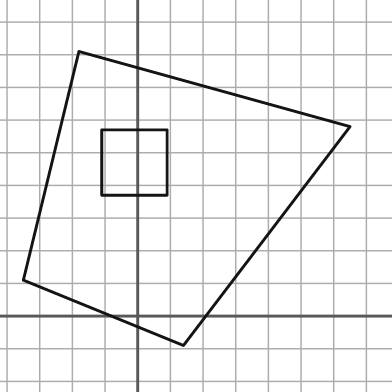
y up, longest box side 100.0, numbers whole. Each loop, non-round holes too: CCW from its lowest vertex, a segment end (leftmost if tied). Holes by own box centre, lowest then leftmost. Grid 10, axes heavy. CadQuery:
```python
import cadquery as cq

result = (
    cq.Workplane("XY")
    .moveTo(14.0, -9.0)
    .lineTo(65.0, 58.0)
    .lineTo(-18.0, 81.0)
    .lineTo(-35.0, 11.0)
    .close()
    .moveTo(-11.0, 37.0)
    .lineTo(9.0, 37.0)
    .lineTo(9.0, 57.0)
    .lineTo(-11.0, 57.0)
    .close()
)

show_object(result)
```